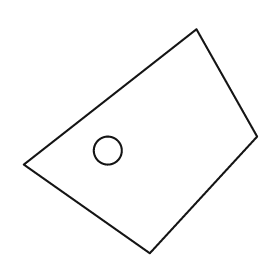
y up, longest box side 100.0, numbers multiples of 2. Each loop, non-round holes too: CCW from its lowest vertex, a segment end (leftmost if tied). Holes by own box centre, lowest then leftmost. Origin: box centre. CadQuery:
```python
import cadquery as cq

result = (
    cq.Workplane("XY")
    .moveTo(4.0, -48.0)
    .lineTo(50.0, 2.0)
    .lineTo(24.0, 48.0)
    .lineTo(-50.0, -10.0)
    .close()
    .moveTo(-14.0, -4.0)
    .circle(6.0)
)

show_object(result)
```